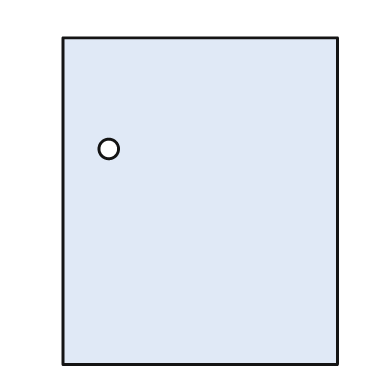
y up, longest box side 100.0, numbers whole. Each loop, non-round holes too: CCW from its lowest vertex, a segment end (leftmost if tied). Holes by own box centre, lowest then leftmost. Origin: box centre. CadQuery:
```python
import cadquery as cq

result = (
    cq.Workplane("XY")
    .moveTo(-42.0, -50.0)
    .lineTo(42.0, -50.0)
    .lineTo(42.0, 50.0)
    .lineTo(-42.0, 50.0)
    .close()
    .moveTo(-28.0, 16.0)
    .circle(3.0)
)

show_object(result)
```